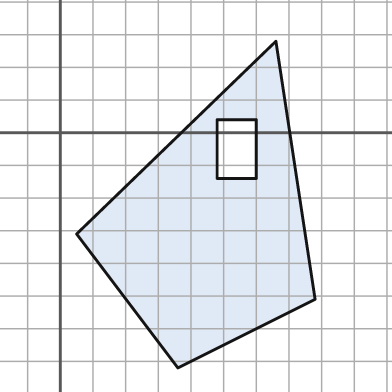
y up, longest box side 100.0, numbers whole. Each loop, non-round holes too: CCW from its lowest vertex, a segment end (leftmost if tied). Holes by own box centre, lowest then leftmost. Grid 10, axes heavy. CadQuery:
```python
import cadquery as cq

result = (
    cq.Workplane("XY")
    .moveTo(36.0, -72.0)
    .lineTo(78.0, -51.0)
    .lineTo(66.0, 28.0)
    .lineTo(5.0, -31.0)
    .close()
    .moveTo(48.0, -14.0)
    .lineTo(60.0, -14.0)
    .lineTo(60.0, 4.0)
    .lineTo(48.0, 4.0)
    .close()
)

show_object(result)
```